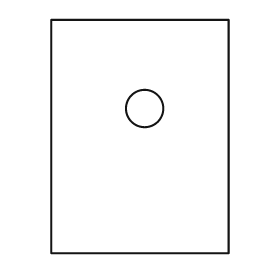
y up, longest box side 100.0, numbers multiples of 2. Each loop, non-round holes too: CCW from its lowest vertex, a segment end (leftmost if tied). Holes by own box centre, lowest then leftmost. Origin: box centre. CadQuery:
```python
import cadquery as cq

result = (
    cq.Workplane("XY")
    .moveTo(-38.0, -50.0)
    .lineTo(38.0, -50.0)
    .lineTo(38.0, 50.0)
    .lineTo(-38.0, 50.0)
    .close()
    .moveTo(2.0, 12.0)
    .circle(8.0)
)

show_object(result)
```